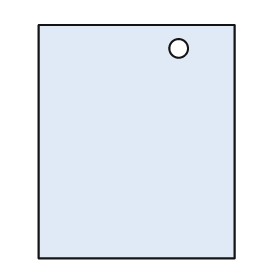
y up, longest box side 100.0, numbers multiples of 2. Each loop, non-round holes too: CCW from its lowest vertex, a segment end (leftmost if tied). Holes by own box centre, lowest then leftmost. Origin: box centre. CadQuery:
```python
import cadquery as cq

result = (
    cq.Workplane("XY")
    .moveTo(-42.0, -50.0)
    .lineTo(42.0, -50.0)
    .lineTo(42.0, 50.0)
    .lineTo(-42.0, 50.0)
    .close()
    .moveTo(18.0, 40.0)
    .circle(4.0)
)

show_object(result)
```